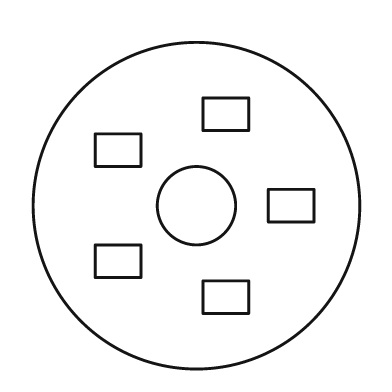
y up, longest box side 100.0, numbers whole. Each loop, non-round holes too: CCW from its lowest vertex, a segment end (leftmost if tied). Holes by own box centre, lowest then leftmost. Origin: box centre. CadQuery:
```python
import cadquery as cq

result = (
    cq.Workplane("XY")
    .moveTo(0.0, 0.0)
    .circle(50.0)
    .moveTo(2.0, -33.0)
    .lineTo(16.0, -33.0)
    .lineTo(16.0, -23.0)
    .lineTo(2.0, -23.0)
    .close()
    .moveTo(-31.0, -22.0)
    .lineTo(-17.0, -22.0)
    .lineTo(-17.0, -12.0)
    .lineTo(-31.0, -12.0)
    .close()
    .moveTo(0.0, 0.0)
    .circle(12.0)
    .moveTo(22.0, -5.0)
    .lineTo(36.0, -5.0)
    .lineTo(36.0, 5.0)
    .lineTo(22.0, 5.0)
    .close()
    .moveTo(-31.0, 12.0)
    .lineTo(-17.0, 12.0)
    .lineTo(-17.0, 22.0)
    .lineTo(-31.0, 22.0)
    .close()
    .moveTo(2.0, 23.0)
    .lineTo(16.0, 23.0)
    .lineTo(16.0, 33.0)
    .lineTo(2.0, 33.0)
    .close()
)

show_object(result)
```